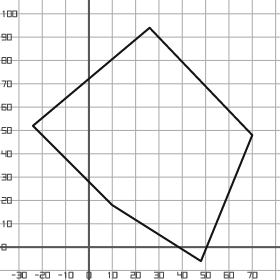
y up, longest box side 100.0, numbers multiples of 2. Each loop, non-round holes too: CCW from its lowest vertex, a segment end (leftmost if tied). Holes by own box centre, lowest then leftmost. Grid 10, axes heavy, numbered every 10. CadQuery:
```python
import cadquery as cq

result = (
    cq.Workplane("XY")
    .moveTo(48.0, -6.0)
    .lineTo(70.0, 48.0)
    .lineTo(26.0, 94.0)
    .lineTo(-24.0, 52.0)
    .lineTo(10.0, 18.0)
    .close()
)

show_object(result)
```